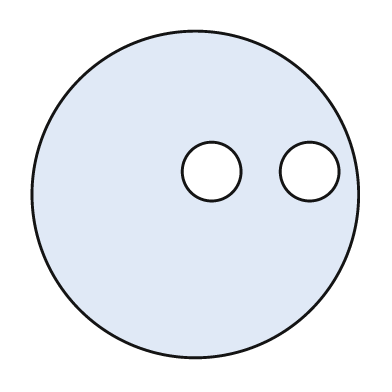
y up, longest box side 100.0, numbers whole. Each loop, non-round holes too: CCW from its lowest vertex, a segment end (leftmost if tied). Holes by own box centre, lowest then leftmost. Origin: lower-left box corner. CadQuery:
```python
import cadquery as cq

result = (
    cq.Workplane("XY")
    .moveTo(50.0, 50.0)
    .circle(50.0)
    .moveTo(55.0, 57.0)
    .circle(9.0)
    .moveTo(85.0, 57.0)
    .circle(9.0)
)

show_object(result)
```